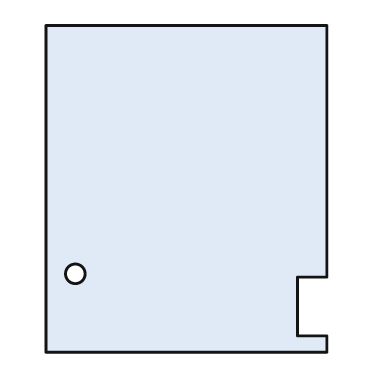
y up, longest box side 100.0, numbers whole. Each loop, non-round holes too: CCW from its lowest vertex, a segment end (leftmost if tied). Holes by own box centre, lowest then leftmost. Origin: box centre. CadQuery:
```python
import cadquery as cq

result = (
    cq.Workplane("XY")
    .moveTo(-43.0, -50.0)
    .lineTo(43.0, -50.0)
    .lineTo(43.0, -45.0)
    .lineTo(34.0, -45.0)
    .lineTo(34.0, -27.0)
    .lineTo(43.0, -27.0)
    .lineTo(43.0, 50.0)
    .lineTo(-43.0, 50.0)
    .close()
    .moveTo(-34.0, -26.0)
    .circle(3.0)
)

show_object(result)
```